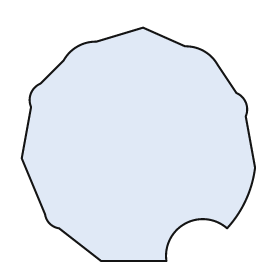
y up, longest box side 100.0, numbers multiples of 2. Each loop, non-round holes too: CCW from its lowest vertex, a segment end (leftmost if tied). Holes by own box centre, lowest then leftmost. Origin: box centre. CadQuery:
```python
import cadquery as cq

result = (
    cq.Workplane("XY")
    .moveTo(-16.0, -50.0)
    .lineTo(12.0, -50.0)
    .threePointArc((20.0, -34.0), (38.0, -36.0))
    .threePointArc((46.0, -24.0), (50.0, -10.0))
    .lineTo(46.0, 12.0)
    .threePointArc((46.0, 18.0), (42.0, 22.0))
    .lineTo(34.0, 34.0)
    .threePointArc((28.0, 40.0), (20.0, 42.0))
    .lineTo(2.0, 50.0)
    .lineTo(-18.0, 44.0)
    .threePointArc((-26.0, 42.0), (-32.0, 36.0))
    .lineTo(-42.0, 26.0)
    .threePointArc((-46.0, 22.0), (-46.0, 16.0))
    .lineTo(-50.0, -6.0)
    .lineTo(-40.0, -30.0)
    .threePointArc((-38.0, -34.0), (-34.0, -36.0))
    .close()
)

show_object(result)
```